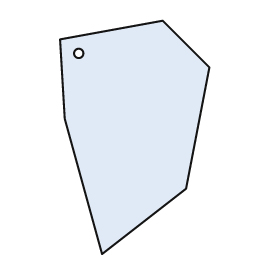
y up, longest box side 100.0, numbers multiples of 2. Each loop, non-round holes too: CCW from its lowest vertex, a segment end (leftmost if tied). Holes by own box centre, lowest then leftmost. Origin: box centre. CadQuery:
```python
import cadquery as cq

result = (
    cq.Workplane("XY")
    .moveTo(-14.0, -50.0)
    .lineTo(22.0, -22.0)
    .lineTo(32.0, 30.0)
    .lineTo(12.0, 50.0)
    .lineTo(-32.0, 42.0)
    .lineTo(-30.0, 8.0)
    .close()
    .moveTo(-24.0, 36.0)
    .circle(2.0)
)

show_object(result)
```